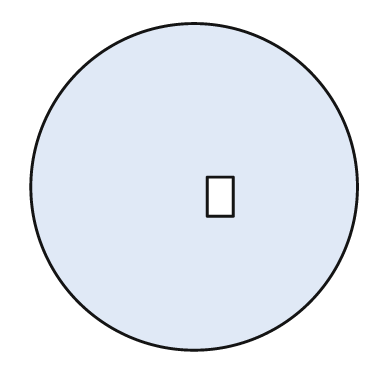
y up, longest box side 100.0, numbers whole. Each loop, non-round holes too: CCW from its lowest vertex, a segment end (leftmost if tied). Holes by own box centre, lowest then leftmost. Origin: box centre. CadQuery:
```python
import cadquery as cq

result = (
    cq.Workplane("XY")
    .moveTo(0.0, 0.0)
    .circle(50.0)
    .moveTo(4.0, -9.0)
    .lineTo(12.0, -9.0)
    .lineTo(12.0, 3.0)
    .lineTo(4.0, 3.0)
    .close()
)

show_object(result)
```